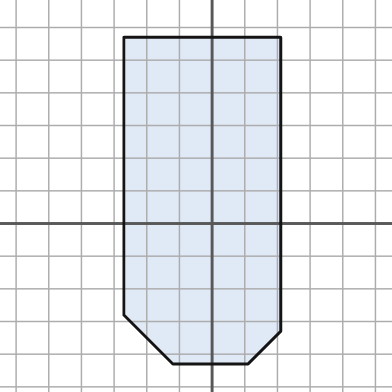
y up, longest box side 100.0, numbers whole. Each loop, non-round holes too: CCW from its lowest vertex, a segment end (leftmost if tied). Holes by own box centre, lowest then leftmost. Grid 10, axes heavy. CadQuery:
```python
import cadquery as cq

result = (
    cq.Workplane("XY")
    .moveTo(-12.0, -43.0)
    .lineTo(11.0, -43.0)
    .lineTo(21.0, -33.0)
    .lineTo(21.0, 57.0)
    .lineTo(-27.0, 57.0)
    .lineTo(-27.0, -28.0)
    .close()
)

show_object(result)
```